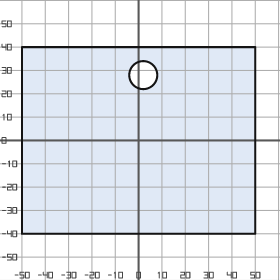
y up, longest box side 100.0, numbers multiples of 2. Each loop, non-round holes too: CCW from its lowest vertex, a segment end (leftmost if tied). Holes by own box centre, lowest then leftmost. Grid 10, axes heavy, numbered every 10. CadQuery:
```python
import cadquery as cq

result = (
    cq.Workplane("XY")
    .moveTo(-50.0, -40.0)
    .lineTo(50.0, -40.0)
    .lineTo(50.0, 40.0)
    .lineTo(-50.0, 40.0)
    .close()
    .moveTo(2.0, 28.0)
    .circle(6.0)
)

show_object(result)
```